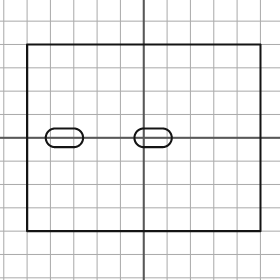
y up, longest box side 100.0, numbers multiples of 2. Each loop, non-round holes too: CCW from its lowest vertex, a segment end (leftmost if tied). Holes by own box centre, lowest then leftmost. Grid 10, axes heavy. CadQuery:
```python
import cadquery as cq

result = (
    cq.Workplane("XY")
    .moveTo(-50.0, -40.0)
    .lineTo(50.0, -40.0)
    .lineTo(50.0, 40.0)
    .lineTo(-50.0, 40.0)
    .close()
    .moveTo(-38.0, -4.0)
    .lineTo(-30.0, -4.0)
    .threePointArc((-26.0, 0.0), (-30.0, 4.0))
    .lineTo(-38.0, 4.0)
    .threePointArc((-42.0, 0.0), (-38.0, -4.0))
    .close()
    .moveTo(0.0, -4.0)
    .lineTo(8.0, -4.0)
    .threePointArc((12.0, 0.0), (8.0, 4.0))
    .lineTo(0.0, 4.0)
    .threePointArc((-4.0, 0.0), (0.0, -4.0))
    .close()
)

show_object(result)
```